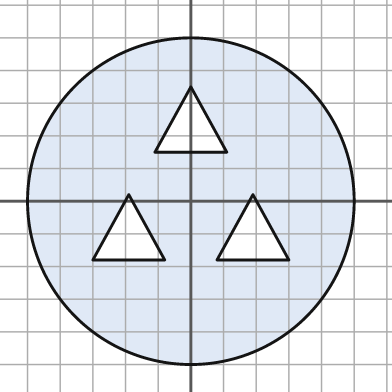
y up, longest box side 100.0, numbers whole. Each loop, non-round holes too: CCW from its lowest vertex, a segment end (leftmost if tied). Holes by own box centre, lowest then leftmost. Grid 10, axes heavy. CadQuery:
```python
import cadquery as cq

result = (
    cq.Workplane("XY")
    .moveTo(0.0, 0.0)
    .circle(50.0)
    .moveTo(-30.0, -18.0)
    .lineTo(-8.0, -18.0)
    .lineTo(-19.0, 2.0)
    .close()
    .moveTo(8.0, -18.0)
    .lineTo(30.0, -18.0)
    .lineTo(19.0, 2.0)
    .close()
    .moveTo(-11.0, 15.0)
    .lineTo(11.0, 15.0)
    .lineTo(0.0, 35.0)
    .close()
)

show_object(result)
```